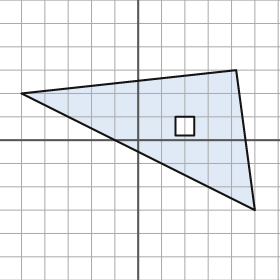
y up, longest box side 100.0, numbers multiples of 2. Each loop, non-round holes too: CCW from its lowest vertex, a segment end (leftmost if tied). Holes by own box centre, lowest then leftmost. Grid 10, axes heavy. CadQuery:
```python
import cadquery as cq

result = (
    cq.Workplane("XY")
    .moveTo(50.0, -30.0)
    .lineTo(42.0, 30.0)
    .lineTo(-50.0, 20.0)
    .close()
    .moveTo(16.0, 2.0)
    .lineTo(24.0, 2.0)
    .lineTo(24.0, 10.0)
    .lineTo(16.0, 10.0)
    .close()
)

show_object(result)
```